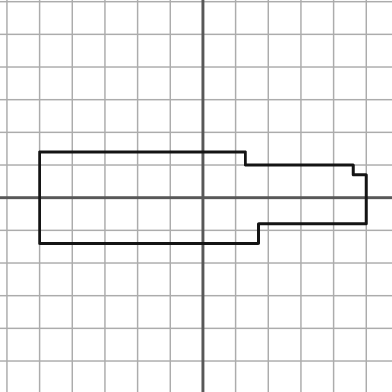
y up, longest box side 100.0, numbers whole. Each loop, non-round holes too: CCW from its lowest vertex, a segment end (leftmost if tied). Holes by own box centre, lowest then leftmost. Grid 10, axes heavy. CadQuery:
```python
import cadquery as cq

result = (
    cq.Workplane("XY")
    .moveTo(-50.0, -14.0)
    .lineTo(17.0, -14.0)
    .lineTo(17.0, -8.0)
    .lineTo(50.0, -8.0)
    .lineTo(50.0, 7.0)
    .lineTo(46.0, 7.0)
    .lineTo(46.0, 10.0)
    .lineTo(13.0, 10.0)
    .lineTo(13.0, 14.0)
    .lineTo(-50.0, 14.0)
    .close()
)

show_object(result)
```